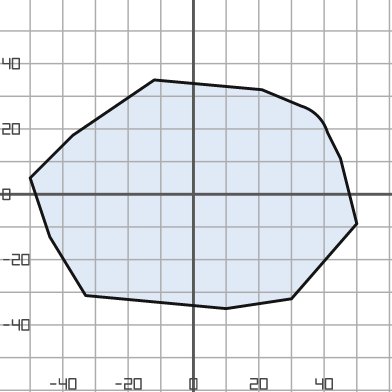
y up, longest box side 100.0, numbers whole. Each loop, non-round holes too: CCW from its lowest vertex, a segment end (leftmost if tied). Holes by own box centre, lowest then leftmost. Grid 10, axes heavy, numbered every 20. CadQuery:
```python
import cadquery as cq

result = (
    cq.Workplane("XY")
    .moveTo(10.0, -35.0)
    .lineTo(30.0, -32.0)
    .lineTo(50.0, -9.0)
    .lineTo(45.0, 11.0)
    .lineTo(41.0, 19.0)
    .threePointArc((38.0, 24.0), (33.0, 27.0))
    .lineTo(21.0, 32.0)
    .lineTo(-12.0, 35.0)
    .lineTo(-37.0, 18.0)
    .lineTo(-50.0, 5.0)
    .lineTo(-44.0, -13.0)
    .lineTo(-33.0, -31.0)
    .close()
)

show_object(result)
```